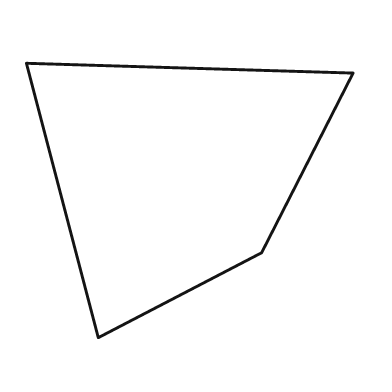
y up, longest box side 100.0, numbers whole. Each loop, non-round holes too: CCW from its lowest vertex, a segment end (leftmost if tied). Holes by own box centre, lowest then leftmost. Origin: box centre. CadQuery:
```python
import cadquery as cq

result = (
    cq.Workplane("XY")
    .moveTo(-28.0, -42.0)
    .lineTo(22.0, -16.0)
    .lineTo(50.0, 39.0)
    .lineTo(-50.0, 42.0)
    .close()
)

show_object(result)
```